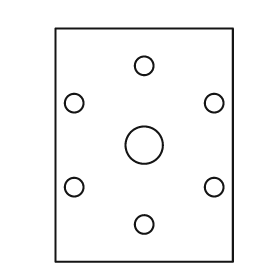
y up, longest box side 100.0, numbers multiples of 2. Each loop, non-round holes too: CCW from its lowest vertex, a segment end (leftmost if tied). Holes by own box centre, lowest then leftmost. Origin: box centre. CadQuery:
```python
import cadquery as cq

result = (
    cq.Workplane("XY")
    .moveTo(-38.0, -50.0)
    .lineTo(38.0, -50.0)
    .lineTo(38.0, 50.0)
    .lineTo(-38.0, 50.0)
    .close()
    .moveTo(0.0, -34.0)
    .circle(4.0)
    .moveTo(-30.0, -18.0)
    .circle(4.0)
    .moveTo(30.0, -18.0)
    .circle(4.0)
    .moveTo(0.0, 0.0)
    .circle(8.0)
    .moveTo(-30.0, 18.0)
    .circle(4.0)
    .moveTo(30.0, 18.0)
    .circle(4.0)
    .moveTo(0.0, 34.0)
    .circle(4.0)
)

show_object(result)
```